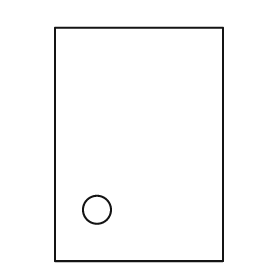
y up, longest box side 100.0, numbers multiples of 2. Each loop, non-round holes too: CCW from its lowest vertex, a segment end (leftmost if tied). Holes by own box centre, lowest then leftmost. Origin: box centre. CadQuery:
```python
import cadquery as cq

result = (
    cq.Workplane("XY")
    .moveTo(-36.0, -50.0)
    .lineTo(36.0, -50.0)
    .lineTo(36.0, 50.0)
    .lineTo(-36.0, 50.0)
    .close()
    .moveTo(-18.0, -28.0)
    .circle(6.0)
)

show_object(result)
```